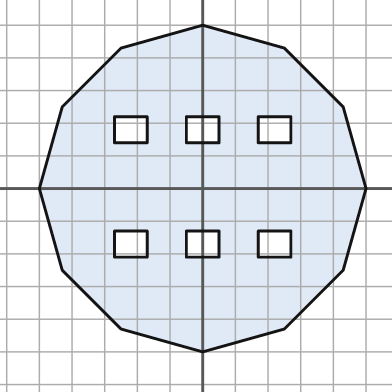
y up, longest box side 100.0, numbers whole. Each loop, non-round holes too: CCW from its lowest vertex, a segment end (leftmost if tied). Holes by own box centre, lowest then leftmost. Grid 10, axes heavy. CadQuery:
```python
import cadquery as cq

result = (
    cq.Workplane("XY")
    .moveTo(0.0, -50.0)
    .lineTo(25.0, -43.0)
    .lineTo(43.0, -25.0)
    .lineTo(50.0, 0.0)
    .lineTo(43.0, 25.0)
    .lineTo(25.0, 43.0)
    .lineTo(0.0, 50.0)
    .lineTo(-25.0, 43.0)
    .lineTo(-43.0, 25.0)
    .lineTo(-50.0, 0.0)
    .lineTo(-43.0, -25.0)
    .lineTo(-25.0, -43.0)
    .close()
    .moveTo(-27.0, -21.0)
    .lineTo(-17.0, -21.0)
    .lineTo(-17.0, -13.0)
    .lineTo(-27.0, -13.0)
    .close()
    .moveTo(-5.0, -21.0)
    .lineTo(5.0, -21.0)
    .lineTo(5.0, -13.0)
    .lineTo(-5.0, -13.0)
    .close()
    .moveTo(17.0, -21.0)
    .lineTo(27.0, -21.0)
    .lineTo(27.0, -13.0)
    .lineTo(17.0, -13.0)
    .close()
    .moveTo(-27.0, 14.0)
    .lineTo(-17.0, 14.0)
    .lineTo(-17.0, 22.0)
    .lineTo(-27.0, 22.0)
    .close()
    .moveTo(-5.0, 14.0)
    .lineTo(5.0, 14.0)
    .lineTo(5.0, 22.0)
    .lineTo(-5.0, 22.0)
    .close()
    .moveTo(17.0, 14.0)
    .lineTo(27.0, 14.0)
    .lineTo(27.0, 22.0)
    .lineTo(17.0, 22.0)
    .close()
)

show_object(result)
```